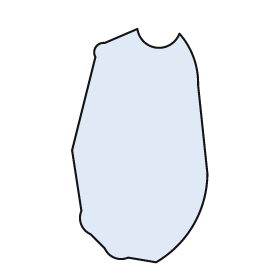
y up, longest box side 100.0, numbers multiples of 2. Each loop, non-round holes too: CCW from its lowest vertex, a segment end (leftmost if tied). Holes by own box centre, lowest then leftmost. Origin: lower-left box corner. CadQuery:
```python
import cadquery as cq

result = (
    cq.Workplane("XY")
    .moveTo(36.0, 0.0)
    .threePointArc((52.0, 16.0), (58.0, 38.0))
    .lineTo(54.0, 76.0)
    .threePointArc((52.0, 88.0), (46.0, 98.0))
    .threePointArc((36.0, 92.0), (28.0, 100.0))
    .lineTo(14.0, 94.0)
    .threePointArc((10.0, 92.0), (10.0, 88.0))
    .lineTo(0.0, 48.0)
    .lineTo(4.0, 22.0)
    .threePointArc((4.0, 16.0), (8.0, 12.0))
    .lineTo(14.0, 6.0)
    .threePointArc((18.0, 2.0), (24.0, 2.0))
    .close()
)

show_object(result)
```